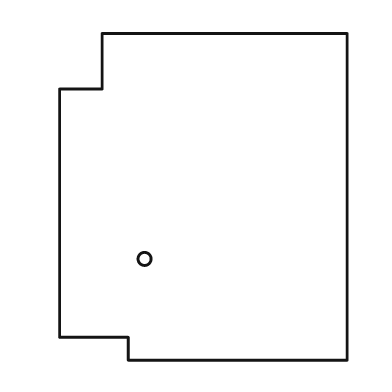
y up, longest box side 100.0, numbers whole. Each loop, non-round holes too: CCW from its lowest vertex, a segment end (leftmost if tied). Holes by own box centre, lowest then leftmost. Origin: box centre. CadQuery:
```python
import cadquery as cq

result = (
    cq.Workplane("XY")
    .moveTo(-23.0, -50.0)
    .lineTo(44.0, -50.0)
    .lineTo(44.0, 50.0)
    .lineTo(-31.0, 50.0)
    .lineTo(-31.0, 33.0)
    .lineTo(-44.0, 33.0)
    .lineTo(-44.0, -43.0)
    .lineTo(-23.0, -43.0)
    .close()
    .moveTo(-18.0, -19.0)
    .circle(2.0)
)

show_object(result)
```